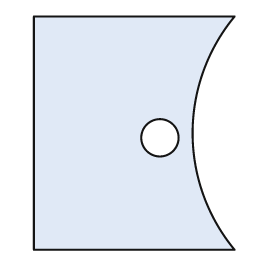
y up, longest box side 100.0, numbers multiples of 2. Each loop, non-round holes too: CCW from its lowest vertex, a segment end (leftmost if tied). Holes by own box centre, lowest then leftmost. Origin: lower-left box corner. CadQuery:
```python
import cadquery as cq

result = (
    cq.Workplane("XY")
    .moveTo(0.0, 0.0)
    .lineTo(86.0, 0.0)
    .threePointArc((68.0, 50.0), (86.0, 100.0))
    .lineTo(0.0, 100.0)
    .close()
    .moveTo(54.0, 48.0)
    .circle(8.0)
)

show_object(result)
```